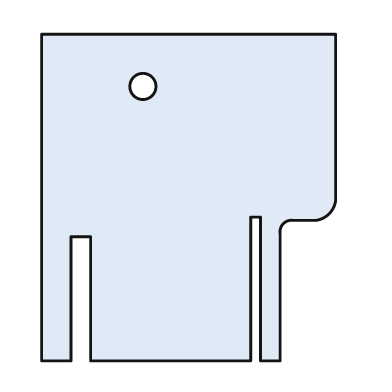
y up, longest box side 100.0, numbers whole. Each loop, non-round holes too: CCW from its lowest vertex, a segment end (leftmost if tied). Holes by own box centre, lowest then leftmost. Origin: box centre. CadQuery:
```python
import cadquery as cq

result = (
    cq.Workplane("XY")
    .moveTo(-45.0, -50.0)
    .lineTo(-36.0, -50.0)
    .lineTo(-36.0, -12.0)
    .lineTo(-30.0, -12.0)
    .lineTo(-30.0, -50.0)
    .lineTo(19.0, -50.0)
    .lineTo(19.0, -6.0)
    .lineTo(22.0, -6.0)
    .lineTo(22.0, -50.0)
    .lineTo(28.0, -50.0)
    .lineTo(28.0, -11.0)
    .threePointArc((29.0, -8.0), (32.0, -7.0))
    .lineTo(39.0, -7.0)
    .threePointArc((43.0, -5.0), (45.0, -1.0))
    .lineTo(45.0, 50.0)
    .lineTo(-45.0, 50.0)
    .close()
    .moveTo(-14.0, 34.0)
    .circle(4.0)
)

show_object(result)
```